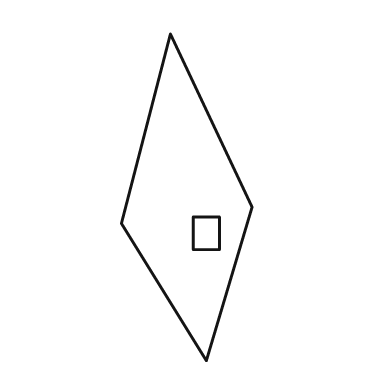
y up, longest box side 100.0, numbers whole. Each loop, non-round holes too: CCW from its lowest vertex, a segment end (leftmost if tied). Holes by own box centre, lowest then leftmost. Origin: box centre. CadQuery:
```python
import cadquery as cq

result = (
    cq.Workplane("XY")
    .moveTo(6.0, -50.0)
    .lineTo(20.0, -3.0)
    .lineTo(-5.0, 50.0)
    .lineTo(-20.0, -8.0)
    .close()
    .moveTo(2.0, -16.0)
    .lineTo(10.0, -16.0)
    .lineTo(10.0, -6.0)
    .lineTo(2.0, -6.0)
    .close()
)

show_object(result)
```